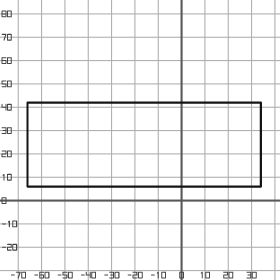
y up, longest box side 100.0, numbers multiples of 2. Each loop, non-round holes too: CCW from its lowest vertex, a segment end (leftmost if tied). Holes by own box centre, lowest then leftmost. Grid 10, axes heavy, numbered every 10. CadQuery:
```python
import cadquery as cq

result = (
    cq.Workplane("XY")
    .moveTo(-66.0, 6.0)
    .lineTo(34.0, 6.0)
    .lineTo(34.0, 42.0)
    .lineTo(-66.0, 42.0)
    .close()
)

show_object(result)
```